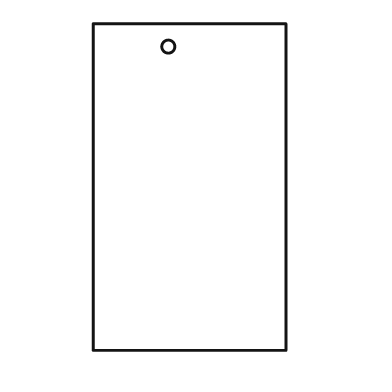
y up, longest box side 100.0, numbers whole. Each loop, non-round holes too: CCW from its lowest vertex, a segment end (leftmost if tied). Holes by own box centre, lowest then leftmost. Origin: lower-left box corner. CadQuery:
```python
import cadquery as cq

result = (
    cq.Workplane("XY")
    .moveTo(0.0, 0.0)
    .lineTo(59.0, 0.0)
    .lineTo(59.0, 100.0)
    .lineTo(0.0, 100.0)
    .close()
    .moveTo(23.0, 93.0)
    .circle(2.0)
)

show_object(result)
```